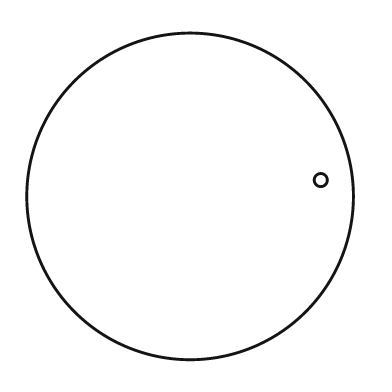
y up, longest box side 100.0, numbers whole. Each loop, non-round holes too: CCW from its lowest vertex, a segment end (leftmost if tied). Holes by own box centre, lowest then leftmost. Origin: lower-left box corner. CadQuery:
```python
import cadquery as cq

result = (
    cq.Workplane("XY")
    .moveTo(50.0, 50.0)
    .circle(50.0)
    .moveTo(90.0, 55.0)
    .circle(2.0)
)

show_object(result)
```